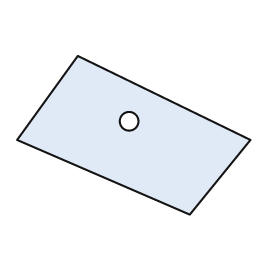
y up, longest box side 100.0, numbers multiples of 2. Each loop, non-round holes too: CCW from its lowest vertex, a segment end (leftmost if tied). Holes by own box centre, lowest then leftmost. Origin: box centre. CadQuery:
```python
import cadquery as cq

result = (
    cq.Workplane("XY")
    .moveTo(24.0, -34.0)
    .lineTo(50.0, -2.0)
    .lineTo(-24.0, 34.0)
    .lineTo(-50.0, -2.0)
    .close()
    .moveTo(-2.0, 6.0)
    .circle(4.0)
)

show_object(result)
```